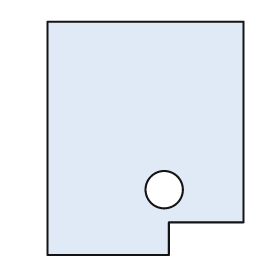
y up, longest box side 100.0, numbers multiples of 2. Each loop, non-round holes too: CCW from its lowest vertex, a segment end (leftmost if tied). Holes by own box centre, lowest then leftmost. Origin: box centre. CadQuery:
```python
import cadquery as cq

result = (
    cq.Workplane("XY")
    .moveTo(-42.0, -50.0)
    .lineTo(10.0, -50.0)
    .lineTo(10.0, -36.0)
    .lineTo(42.0, -36.0)
    .lineTo(42.0, 50.0)
    .lineTo(-42.0, 50.0)
    .close()
    .moveTo(8.0, -22.0)
    .circle(8.0)
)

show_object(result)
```